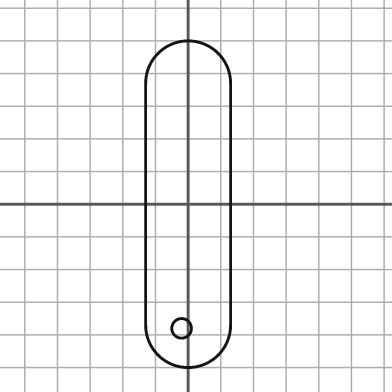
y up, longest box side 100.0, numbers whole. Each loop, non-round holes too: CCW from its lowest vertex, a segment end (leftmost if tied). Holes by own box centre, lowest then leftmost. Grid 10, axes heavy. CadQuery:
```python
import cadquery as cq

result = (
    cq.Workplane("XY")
    .moveTo(-13.0, -37.0)
    .threePointArc((0.0, -50.0), (13.0, -37.0))
    .lineTo(13.0, 37.0)
    .threePointArc((0.0, 50.0), (-13.0, 37.0))
    .close()
    .moveTo(-2.0, -38.0)
    .circle(3.0)
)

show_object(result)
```